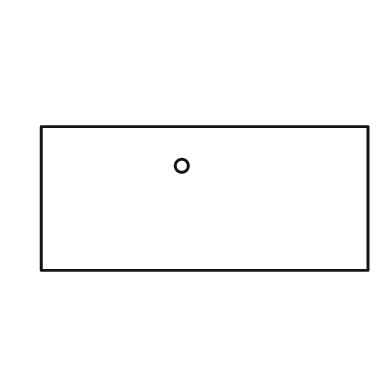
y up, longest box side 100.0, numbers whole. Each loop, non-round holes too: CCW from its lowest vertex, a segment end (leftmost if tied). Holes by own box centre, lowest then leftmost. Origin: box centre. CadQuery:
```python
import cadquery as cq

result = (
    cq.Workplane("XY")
    .moveTo(-50.0, -22.0)
    .lineTo(50.0, -22.0)
    .lineTo(50.0, 22.0)
    .lineTo(-50.0, 22.0)
    .close()
    .moveTo(-7.0, 10.0)
    .circle(2.0)
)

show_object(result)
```